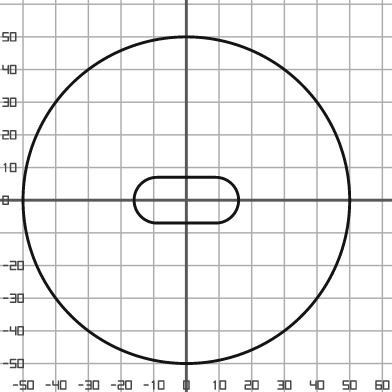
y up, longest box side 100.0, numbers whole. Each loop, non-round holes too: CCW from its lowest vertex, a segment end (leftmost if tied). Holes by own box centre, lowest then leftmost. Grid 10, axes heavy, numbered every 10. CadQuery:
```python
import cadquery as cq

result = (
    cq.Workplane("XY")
    .moveTo(0.0, 0.0)
    .circle(50.0)
    .moveTo(-9.0, -7.0)
    .lineTo(9.0, -7.0)
    .threePointArc((16.0, 0.0), (9.0, 7.0))
    .lineTo(-9.0, 7.0)
    .threePointArc((-16.0, 0.0), (-9.0, -7.0))
    .close()
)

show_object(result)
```